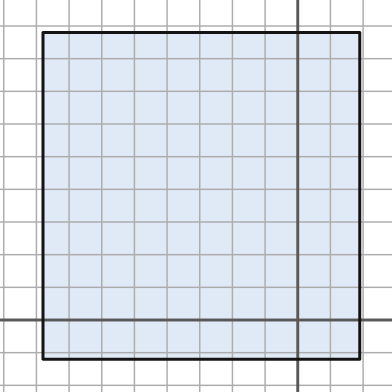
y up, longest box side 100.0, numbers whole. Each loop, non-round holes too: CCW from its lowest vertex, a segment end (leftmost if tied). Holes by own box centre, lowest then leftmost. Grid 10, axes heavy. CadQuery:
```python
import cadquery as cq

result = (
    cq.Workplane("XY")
    .moveTo(-78.0, -12.0)
    .lineTo(19.0, -12.0)
    .lineTo(19.0, 88.0)
    .lineTo(-78.0, 88.0)
    .close()
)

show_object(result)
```